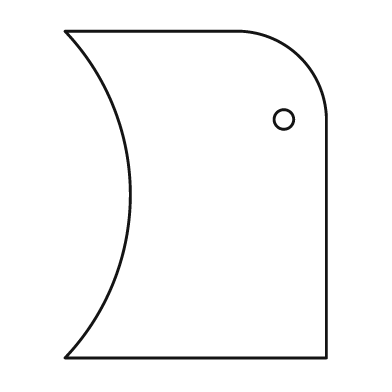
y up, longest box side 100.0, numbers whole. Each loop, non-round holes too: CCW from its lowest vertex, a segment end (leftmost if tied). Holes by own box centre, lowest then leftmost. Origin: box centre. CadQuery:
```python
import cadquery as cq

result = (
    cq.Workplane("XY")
    .moveTo(-40.0, -50.0)
    .lineTo(40.0, -50.0)
    .lineTo(40.0, 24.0)
    .threePointArc((32.0, 42.0), (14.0, 50.0))
    .lineTo(-40.0, 50.0)
    .threePointArc((-20.0, 0.0), (-40.0, -50.0))
    .close()
    .moveTo(27.0, 23.0)
    .circle(3.0)
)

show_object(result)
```